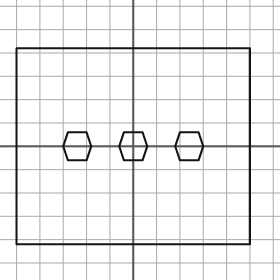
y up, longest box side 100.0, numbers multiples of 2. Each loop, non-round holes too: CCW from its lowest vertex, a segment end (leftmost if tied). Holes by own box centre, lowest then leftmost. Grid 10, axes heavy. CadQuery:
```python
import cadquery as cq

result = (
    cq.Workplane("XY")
    .moveTo(-50.0, -42.0)
    .lineTo(50.0, -42.0)
    .lineTo(50.0, 42.0)
    .lineTo(-50.0, 42.0)
    .close()
    .moveTo(-28.0, -6.0)
    .lineTo(-20.0, -6.0)
    .lineTo(-18.0, 0.0)
    .lineTo(-20.0, 6.0)
    .lineTo(-28.0, 6.0)
    .lineTo(-30.0, 0.0)
    .close()
    .moveTo(-4.0, -6.0)
    .lineTo(4.0, -6.0)
    .lineTo(6.0, 0.0)
    .lineTo(4.0, 6.0)
    .lineTo(-4.0, 6.0)
    .lineTo(-6.0, 0.0)
    .close()
    .moveTo(20.0, -6.0)
    .lineTo(28.0, -6.0)
    .lineTo(30.0, 0.0)
    .lineTo(28.0, 6.0)
    .lineTo(20.0, 6.0)
    .lineTo(18.0, 0.0)
    .close()
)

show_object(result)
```